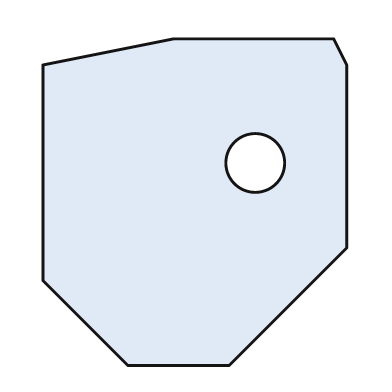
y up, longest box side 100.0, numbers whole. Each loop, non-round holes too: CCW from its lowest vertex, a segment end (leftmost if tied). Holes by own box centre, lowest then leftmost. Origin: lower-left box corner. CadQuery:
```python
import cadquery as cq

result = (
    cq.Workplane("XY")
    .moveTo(26.0, 0.0)
    .lineTo(57.0, 0.0)
    .lineTo(93.0, 36.0)
    .lineTo(93.0, 92.0)
    .lineTo(89.0, 100.0)
    .lineTo(40.0, 100.0)
    .lineTo(0.0, 92.0)
    .lineTo(0.0, 26.0)
    .close()
    .moveTo(65.0, 62.0)
    .circle(9.0)
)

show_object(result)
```